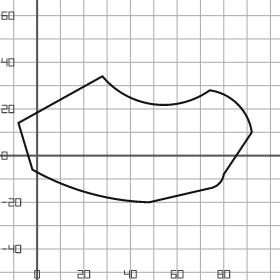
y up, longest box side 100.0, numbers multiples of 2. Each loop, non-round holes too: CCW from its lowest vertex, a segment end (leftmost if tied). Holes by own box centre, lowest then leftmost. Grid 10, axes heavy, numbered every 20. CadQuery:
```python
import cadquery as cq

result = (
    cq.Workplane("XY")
    .moveTo(48.0, -20.0)
    .lineTo(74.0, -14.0)
    .threePointArc((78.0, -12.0), (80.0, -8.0))
    .lineTo(92.0, 10.0)
    .threePointArc((86.0, 22.0), (74.0, 28.0))
    .threePointArc((50.0, 22.0), (28.0, 34.0))
    .lineTo(-8.0, 14.0)
    .lineTo(-2.0, -6.0)
    .threePointArc((22.0, -16.0), (48.0, -20.0))
    .close()
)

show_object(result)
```